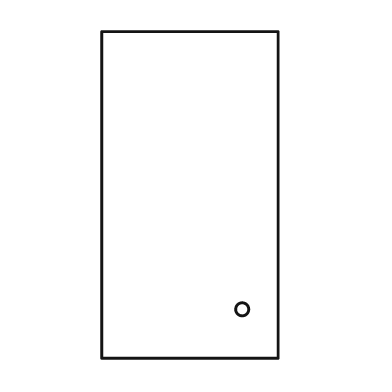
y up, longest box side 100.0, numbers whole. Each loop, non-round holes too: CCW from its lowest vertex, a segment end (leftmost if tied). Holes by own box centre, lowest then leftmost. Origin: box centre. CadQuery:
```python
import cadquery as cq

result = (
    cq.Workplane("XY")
    .moveTo(-27.0, -50.0)
    .lineTo(27.0, -50.0)
    .lineTo(27.0, 50.0)
    .lineTo(-27.0, 50.0)
    .close()
    .moveTo(16.0, -35.0)
    .circle(2.0)
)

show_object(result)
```